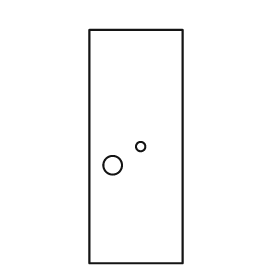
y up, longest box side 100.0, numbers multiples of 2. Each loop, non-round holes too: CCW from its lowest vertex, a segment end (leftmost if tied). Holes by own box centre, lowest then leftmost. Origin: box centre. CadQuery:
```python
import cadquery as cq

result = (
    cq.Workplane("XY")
    .moveTo(-20.0, -50.0)
    .lineTo(20.0, -50.0)
    .lineTo(20.0, 50.0)
    .lineTo(-20.0, 50.0)
    .close()
    .moveTo(-10.0, -8.0)
    .circle(4.0)
    .moveTo(2.0, 0.0)
    .circle(2.0)
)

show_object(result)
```